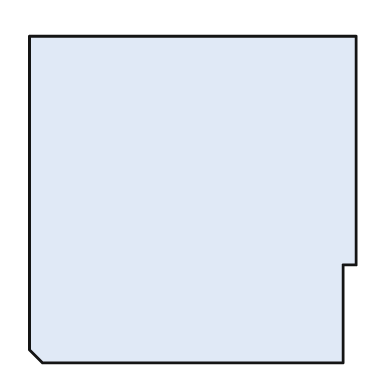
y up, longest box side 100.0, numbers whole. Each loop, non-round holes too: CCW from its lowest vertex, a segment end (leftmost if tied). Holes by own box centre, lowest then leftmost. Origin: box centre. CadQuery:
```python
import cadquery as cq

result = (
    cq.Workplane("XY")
    .moveTo(-46.0, -50.0)
    .lineTo(46.0, -50.0)
    .lineTo(46.0, -20.0)
    .lineTo(50.0, -20.0)
    .lineTo(50.0, 50.0)
    .lineTo(-50.0, 50.0)
    .lineTo(-50.0, -46.0)
    .close()
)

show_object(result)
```